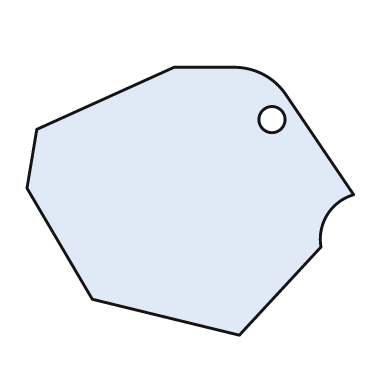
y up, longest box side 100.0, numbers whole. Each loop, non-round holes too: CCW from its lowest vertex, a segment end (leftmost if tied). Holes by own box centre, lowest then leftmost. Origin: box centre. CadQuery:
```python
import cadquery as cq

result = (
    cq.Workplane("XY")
    .moveTo(15.0, -41.0)
    .lineTo(40.0, -14.0)
    .threePointArc((42.0, -4.0), (50.0, 2.0))
    .lineTo(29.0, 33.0)
    .threePointArc((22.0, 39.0), (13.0, 41.0))
    .lineTo(-5.0, 41.0)
    .lineTo(-47.0, 22.0)
    .lineTo(-50.0, 4.0)
    .lineTo(-30.0, -30.0)
    .close()
    .moveTo(25.0, 25.0)
    .circle(4.0)
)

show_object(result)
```